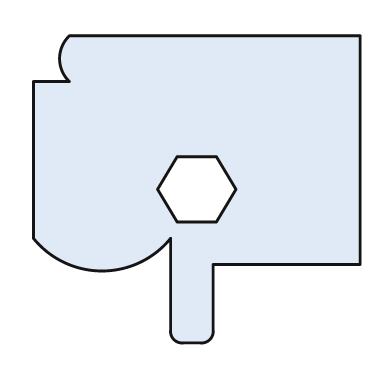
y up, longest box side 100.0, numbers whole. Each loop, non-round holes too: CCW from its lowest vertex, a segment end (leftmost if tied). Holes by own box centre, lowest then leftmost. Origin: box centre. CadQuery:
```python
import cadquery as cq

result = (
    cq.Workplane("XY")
    .moveTo(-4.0, -47.0)
    .lineTo(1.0, -47.0)
    .threePointArc((4.0, -46.0), (5.0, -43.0))
    .lineTo(5.0, -23.0)
    .lineTo(50.0, -23.0)
    .lineTo(50.0, 47.0)
    .lineTo(-39.0, 47.0)
    .threePointArc((-42.0, 40.0), (-39.0, 33.0))
    .lineTo(-50.0, 33.0)
    .lineTo(-50.0, -15.0)
    .threePointArc((-29.0, -25.0), (-8.0, -15.0))
    .lineTo(-8.0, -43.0)
    .threePointArc((-7.0, -46.0), (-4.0, -47.0))
    .close()
    .moveTo(-6.0, -10.0)
    .lineTo(6.0, -10.0)
    .lineTo(12.0, 0.0)
    .lineTo(6.0, 10.0)
    .lineTo(-6.0, 10.0)
    .lineTo(-12.0, 0.0)
    .close()
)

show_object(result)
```